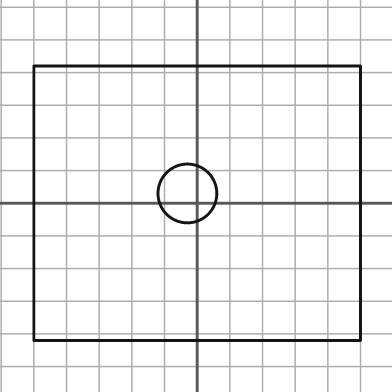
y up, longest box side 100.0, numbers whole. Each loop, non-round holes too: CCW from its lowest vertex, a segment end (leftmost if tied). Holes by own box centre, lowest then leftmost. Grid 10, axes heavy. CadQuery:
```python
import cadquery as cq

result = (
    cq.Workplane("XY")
    .moveTo(-50.0, -42.0)
    .lineTo(50.0, -42.0)
    .lineTo(50.0, 42.0)
    .lineTo(-50.0, 42.0)
    .close()
    .moveTo(-3.0, 3.0)
    .circle(9.0)
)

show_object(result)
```